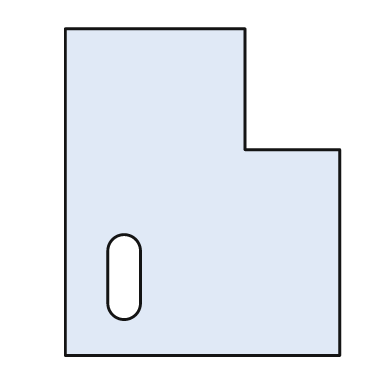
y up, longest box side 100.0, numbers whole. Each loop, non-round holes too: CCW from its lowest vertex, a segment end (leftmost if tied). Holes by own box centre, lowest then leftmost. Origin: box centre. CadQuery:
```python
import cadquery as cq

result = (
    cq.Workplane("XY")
    .moveTo(-42.0, -50.0)
    .lineTo(42.0, -50.0)
    .lineTo(42.0, 13.0)
    .lineTo(13.0, 13.0)
    .lineTo(13.0, 50.0)
    .lineTo(-42.0, 50.0)
    .close()
    .moveTo(-29.0, -34.0)
    .threePointArc((-24.0, -39.0), (-19.0, -34.0))
    .lineTo(-19.0, -18.0)
    .threePointArc((-24.0, -13.0), (-29.0, -18.0))
    .close()
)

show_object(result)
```